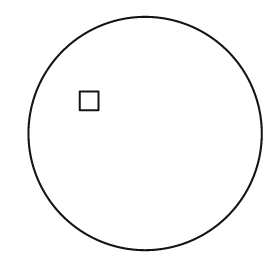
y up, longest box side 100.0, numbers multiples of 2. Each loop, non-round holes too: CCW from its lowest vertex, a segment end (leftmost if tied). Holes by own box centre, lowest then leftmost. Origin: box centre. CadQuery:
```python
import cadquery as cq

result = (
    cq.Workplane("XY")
    .moveTo(0.0, 0.0)
    .circle(50.0)
    .moveTo(-28.0, 10.0)
    .lineTo(-20.0, 10.0)
    .lineTo(-20.0, 18.0)
    .lineTo(-28.0, 18.0)
    .close()
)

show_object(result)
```